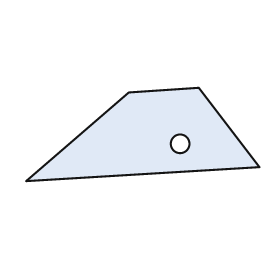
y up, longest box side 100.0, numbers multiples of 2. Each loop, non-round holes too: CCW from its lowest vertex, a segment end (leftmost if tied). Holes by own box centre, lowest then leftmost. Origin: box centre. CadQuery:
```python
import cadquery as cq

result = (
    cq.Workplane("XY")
    .moveTo(-50.0, -20.0)
    .lineTo(50.0, -14.0)
    .lineTo(24.0, 20.0)
    .lineTo(-6.0, 18.0)
    .close()
    .moveTo(16.0, -4.0)
    .circle(4.0)
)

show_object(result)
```